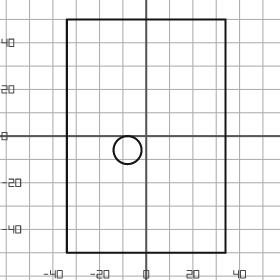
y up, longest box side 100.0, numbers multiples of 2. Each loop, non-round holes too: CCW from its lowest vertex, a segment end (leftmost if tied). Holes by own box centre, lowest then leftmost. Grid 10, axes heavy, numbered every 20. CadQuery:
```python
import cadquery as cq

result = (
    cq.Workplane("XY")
    .moveTo(-34.0, -50.0)
    .lineTo(34.0, -50.0)
    .lineTo(34.0, 50.0)
    .lineTo(-34.0, 50.0)
    .close()
    .moveTo(-8.0, -6.0)
    .circle(6.0)
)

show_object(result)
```